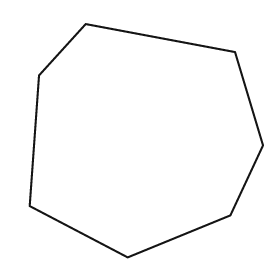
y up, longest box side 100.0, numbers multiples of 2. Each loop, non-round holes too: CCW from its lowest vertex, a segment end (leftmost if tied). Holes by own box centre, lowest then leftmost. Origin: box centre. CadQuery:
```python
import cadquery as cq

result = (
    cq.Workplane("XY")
    .moveTo(-8.0, -50.0)
    .lineTo(36.0, -32.0)
    .lineTo(50.0, -2.0)
    .lineTo(38.0, 38.0)
    .lineTo(-26.0, 50.0)
    .lineTo(-46.0, 28.0)
    .lineTo(-50.0, -28.0)
    .close()
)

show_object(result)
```